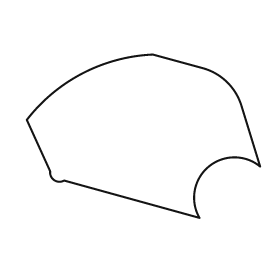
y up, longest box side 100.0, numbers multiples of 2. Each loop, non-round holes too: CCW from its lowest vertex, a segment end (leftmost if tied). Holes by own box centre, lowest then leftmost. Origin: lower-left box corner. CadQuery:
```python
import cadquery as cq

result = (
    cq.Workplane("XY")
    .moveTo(74.0, 0.0)
    .threePointArc((78.0, 22.0), (100.0, 22.0))
    .lineTo(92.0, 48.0)
    .threePointArc((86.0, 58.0), (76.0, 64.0))
    .lineTo(54.0, 70.0)
    .threePointArc((24.0, 62.0), (0.0, 42.0))
    .lineTo(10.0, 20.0)
    .threePointArc((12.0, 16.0), (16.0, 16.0))
    .close()
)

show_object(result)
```